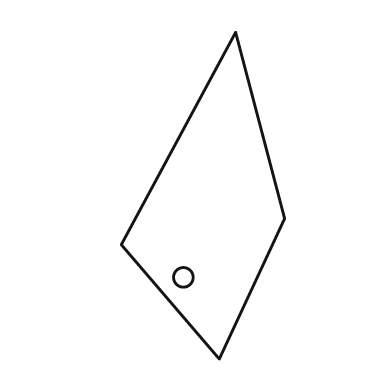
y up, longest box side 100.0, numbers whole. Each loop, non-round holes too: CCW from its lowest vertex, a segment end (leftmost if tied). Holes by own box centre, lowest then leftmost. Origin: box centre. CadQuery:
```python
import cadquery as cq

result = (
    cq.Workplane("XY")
    .moveTo(5.0, -50.0)
    .lineTo(25.0, -7.0)
    .lineTo(10.0, 50.0)
    .lineTo(-25.0, -15.0)
    .close()
    .moveTo(-6.0, -25.0)
    .circle(3.0)
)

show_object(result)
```